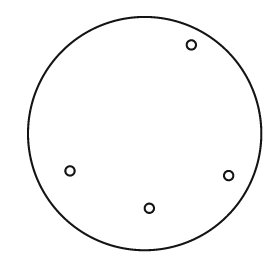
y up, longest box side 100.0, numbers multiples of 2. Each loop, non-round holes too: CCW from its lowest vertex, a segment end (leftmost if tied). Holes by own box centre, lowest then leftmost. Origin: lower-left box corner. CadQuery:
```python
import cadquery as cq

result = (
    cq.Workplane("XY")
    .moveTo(50.0, 50.0)
    .circle(50.0)
    .moveTo(52.0, 18.0)
    .circle(2.0)
    .moveTo(86.0, 32.0)
    .circle(2.0)
    .moveTo(18.0, 34.0)
    .circle(2.0)
    .moveTo(70.0, 88.0)
    .circle(2.0)
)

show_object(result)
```